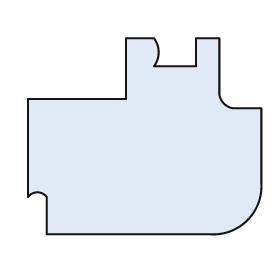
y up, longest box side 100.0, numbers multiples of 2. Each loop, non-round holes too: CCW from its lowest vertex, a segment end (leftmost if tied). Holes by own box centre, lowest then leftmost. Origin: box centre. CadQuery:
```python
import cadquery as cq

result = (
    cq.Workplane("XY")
    .moveTo(-42.0, -42.0)
    .lineTo(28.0, -42.0)
    .threePointArc((44.0, -36.0), (50.0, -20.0))
    .lineTo(50.0, 12.0)
    .lineTo(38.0, 12.0)
    .threePointArc((34.0, 14.0), (32.0, 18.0))
    .lineTo(32.0, 42.0)
    .lineTo(22.0, 42.0)
    .lineTo(22.0, 30.0)
    .lineTo(4.0, 30.0)
    .threePointArc((6.0, 36.0), (4.0, 42.0))
    .lineTo(-8.0, 42.0)
    .lineTo(-8.0, 16.0)
    .lineTo(-50.0, 16.0)
    .lineTo(-50.0, -26.0)
    .threePointArc((-46.0, -24.0), (-42.0, -26.0))
    .close()
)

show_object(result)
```